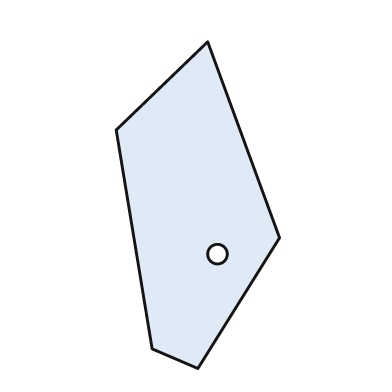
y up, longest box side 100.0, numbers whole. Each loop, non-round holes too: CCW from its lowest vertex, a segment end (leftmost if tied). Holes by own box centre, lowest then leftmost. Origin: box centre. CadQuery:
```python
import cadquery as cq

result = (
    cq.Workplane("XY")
    .moveTo(0.0, -50.0)
    .lineTo(25.0, -10.0)
    .lineTo(3.0, 50.0)
    .lineTo(-25.0, 23.0)
    .lineTo(-14.0, -44.0)
    .close()
    .moveTo(6.0, -15.0)
    .circle(3.0)
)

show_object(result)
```